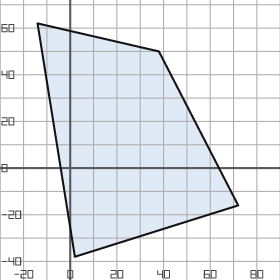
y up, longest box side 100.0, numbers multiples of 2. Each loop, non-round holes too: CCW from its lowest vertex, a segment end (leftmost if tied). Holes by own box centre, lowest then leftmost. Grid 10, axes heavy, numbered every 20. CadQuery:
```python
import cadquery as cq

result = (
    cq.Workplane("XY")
    .moveTo(2.0, -38.0)
    .lineTo(72.0, -16.0)
    .lineTo(38.0, 50.0)
    .lineTo(-14.0, 62.0)
    .close()
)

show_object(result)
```